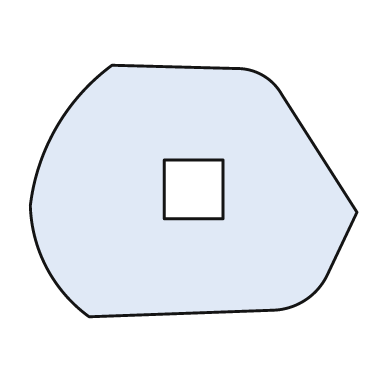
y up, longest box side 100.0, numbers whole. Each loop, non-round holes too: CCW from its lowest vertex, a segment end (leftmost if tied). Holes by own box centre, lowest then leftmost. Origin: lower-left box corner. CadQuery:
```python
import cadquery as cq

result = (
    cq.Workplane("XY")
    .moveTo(18.0, 0.0)
    .lineTo(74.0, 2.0)
    .threePointArc((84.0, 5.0), (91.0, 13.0))
    .lineTo(100.0, 32.0)
    .lineTo(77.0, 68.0)
    .threePointArc((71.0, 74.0), (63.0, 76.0))
    .lineTo(25.0, 77.0)
    .threePointArc((8.0, 58.0), (0.0, 34.0))
    .threePointArc((5.0, 15.0), (18.0, 0.0))
    .close()
    .moveTo(41.0, 30.0)
    .lineTo(59.0, 30.0)
    .lineTo(59.0, 48.0)
    .lineTo(41.0, 48.0)
    .close()
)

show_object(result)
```